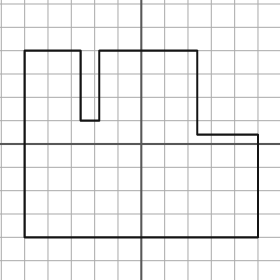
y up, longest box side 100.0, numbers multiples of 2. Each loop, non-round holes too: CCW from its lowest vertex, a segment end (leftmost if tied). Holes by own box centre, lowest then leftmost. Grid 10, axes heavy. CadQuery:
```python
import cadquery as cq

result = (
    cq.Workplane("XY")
    .moveTo(-50.0, -40.0)
    .lineTo(50.0, -40.0)
    .lineTo(50.0, 4.0)
    .lineTo(24.0, 4.0)
    .lineTo(24.0, 40.0)
    .lineTo(-18.0, 40.0)
    .lineTo(-18.0, 10.0)
    .lineTo(-26.0, 10.0)
    .lineTo(-26.0, 40.0)
    .lineTo(-50.0, 40.0)
    .close()
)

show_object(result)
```